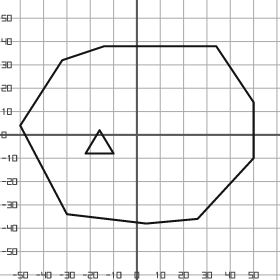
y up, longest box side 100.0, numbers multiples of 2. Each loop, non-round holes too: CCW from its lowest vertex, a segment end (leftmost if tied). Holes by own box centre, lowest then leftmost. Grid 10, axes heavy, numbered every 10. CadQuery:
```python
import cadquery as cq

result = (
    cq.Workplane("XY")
    .moveTo(4.0, -38.0)
    .lineTo(26.0, -36.0)
    .lineTo(50.0, -10.0)
    .lineTo(50.0, 14.0)
    .lineTo(34.0, 38.0)
    .lineTo(-14.0, 38.0)
    .lineTo(-32.0, 32.0)
    .lineTo(-50.0, 4.0)
    .lineTo(-30.0, -34.0)
    .close()
    .moveTo(-22.0, -8.0)
    .lineTo(-10.0, -8.0)
    .lineTo(-16.0, 2.0)
    .close()
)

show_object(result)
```